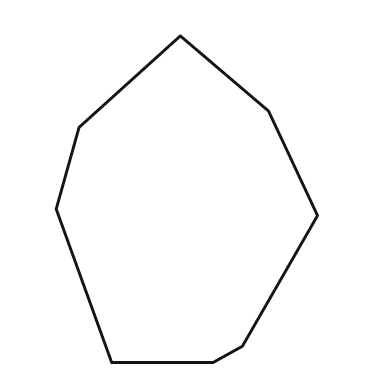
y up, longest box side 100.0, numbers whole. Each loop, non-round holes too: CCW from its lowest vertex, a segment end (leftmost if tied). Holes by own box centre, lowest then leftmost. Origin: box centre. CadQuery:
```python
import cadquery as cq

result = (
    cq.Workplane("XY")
    .moveTo(-23.0, -50.0)
    .lineTo(8.0, -50.0)
    .lineTo(17.0, -45.0)
    .lineTo(40.0, -5.0)
    .lineTo(25.0, 27.0)
    .lineTo(-2.0, 50.0)
    .lineTo(-33.0, 22.0)
    .lineTo(-40.0, -3.0)
    .close()
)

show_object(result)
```